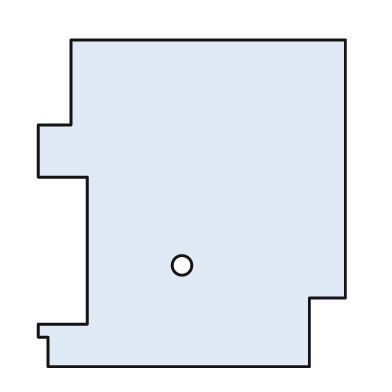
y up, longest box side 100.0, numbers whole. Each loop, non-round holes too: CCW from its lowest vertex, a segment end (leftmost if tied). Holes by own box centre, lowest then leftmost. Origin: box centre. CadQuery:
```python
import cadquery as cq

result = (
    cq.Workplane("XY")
    .moveTo(-44.0, -50.0)
    .lineTo(36.0, -50.0)
    .lineTo(36.0, -29.0)
    .lineTo(47.0, -29.0)
    .lineTo(47.0, 50.0)
    .lineTo(-37.0, 50.0)
    .lineTo(-37.0, 24.0)
    .lineTo(-47.0, 24.0)
    .lineTo(-47.0, 8.0)
    .lineTo(-32.0, 8.0)
    .lineTo(-32.0, -37.0)
    .lineTo(-47.0, -37.0)
    .lineTo(-47.0, -41.0)
    .lineTo(-44.0, -41.0)
    .close()
    .moveTo(-3.0, -19.0)
    .circle(3.0)
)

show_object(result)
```